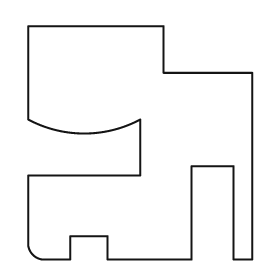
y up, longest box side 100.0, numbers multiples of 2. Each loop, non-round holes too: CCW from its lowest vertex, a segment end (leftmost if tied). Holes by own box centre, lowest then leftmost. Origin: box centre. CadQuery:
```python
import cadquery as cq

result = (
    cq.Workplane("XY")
    .moveTo(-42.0, -50.0)
    .lineTo(-30.0, -50.0)
    .lineTo(-30.0, -40.0)
    .lineTo(-14.0, -40.0)
    .lineTo(-14.0, -50.0)
    .lineTo(22.0, -50.0)
    .lineTo(22.0, -10.0)
    .lineTo(40.0, -10.0)
    .lineTo(40.0, -50.0)
    .lineTo(48.0, -50.0)
    .lineTo(48.0, 30.0)
    .lineTo(10.0, 30.0)
    .lineTo(10.0, 50.0)
    .lineTo(-48.0, 50.0)
    .lineTo(-48.0, 10.0)
    .threePointArc((-24.0, 4.0), (0.0, 10.0))
    .lineTo(0.0, -14.0)
    .lineTo(-48.0, -14.0)
    .lineTo(-48.0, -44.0)
    .threePointArc((-46.0, -48.0), (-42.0, -50.0))
    .close()
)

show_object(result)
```